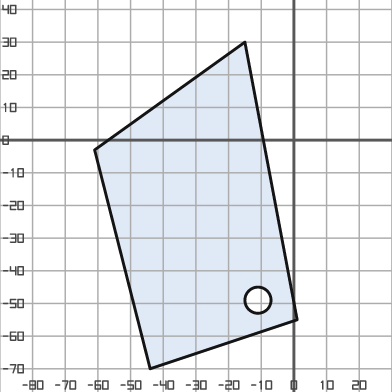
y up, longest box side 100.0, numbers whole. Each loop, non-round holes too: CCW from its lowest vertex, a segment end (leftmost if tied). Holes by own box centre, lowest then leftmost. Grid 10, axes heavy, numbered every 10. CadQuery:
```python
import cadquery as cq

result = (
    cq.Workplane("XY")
    .moveTo(-44.0, -70.0)
    .lineTo(1.0, -55.0)
    .lineTo(-15.0, 30.0)
    .lineTo(-61.0, -3.0)
    .close()
    .moveTo(-11.0, -49.0)
    .circle(4.0)
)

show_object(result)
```